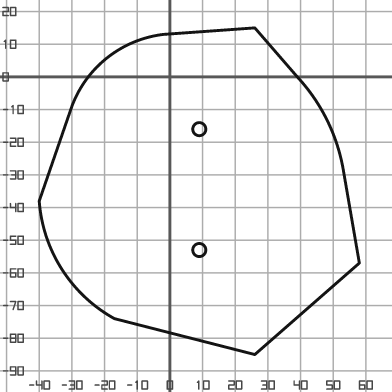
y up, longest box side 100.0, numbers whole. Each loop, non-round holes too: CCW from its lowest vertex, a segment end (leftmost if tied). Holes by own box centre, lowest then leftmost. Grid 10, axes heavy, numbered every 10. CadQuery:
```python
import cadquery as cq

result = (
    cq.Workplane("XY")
    .moveTo(26.0, -85.0)
    .lineTo(58.0, -57.0)
    .lineTo(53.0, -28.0)
    .threePointArc((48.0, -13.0), (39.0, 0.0))
    .lineTo(26.0, 15.0)
    .lineTo(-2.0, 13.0)
    .threePointArc((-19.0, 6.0), (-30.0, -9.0))
    .lineTo(-40.0, -38.0)
    .threePointArc((-33.0, -59.0), (-17.0, -74.0))
    .close()
    .moveTo(9.0, -53.0)
    .circle(2.0)
    .moveTo(9.0, -16.0)
    .circle(2.0)
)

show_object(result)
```